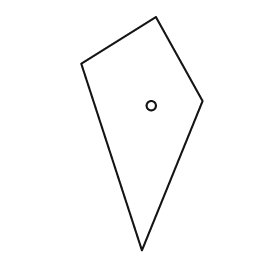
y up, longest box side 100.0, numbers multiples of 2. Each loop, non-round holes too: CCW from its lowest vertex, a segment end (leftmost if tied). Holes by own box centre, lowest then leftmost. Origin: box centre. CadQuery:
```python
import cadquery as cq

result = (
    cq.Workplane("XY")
    .moveTo(0.0, -50.0)
    .lineTo(26.0, 14.0)
    .lineTo(6.0, 50.0)
    .lineTo(-26.0, 30.0)
    .close()
    .moveTo(4.0, 12.0)
    .circle(2.0)
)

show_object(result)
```